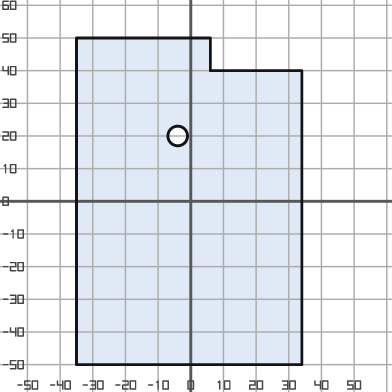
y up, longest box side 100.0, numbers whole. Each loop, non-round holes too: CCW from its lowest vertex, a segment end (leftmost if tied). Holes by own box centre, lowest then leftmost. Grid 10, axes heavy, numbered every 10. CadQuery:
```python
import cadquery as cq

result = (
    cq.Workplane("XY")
    .moveTo(-35.0, -50.0)
    .lineTo(34.0, -50.0)
    .lineTo(34.0, 40.0)
    .lineTo(6.0, 40.0)
    .lineTo(6.0, 50.0)
    .lineTo(-35.0, 50.0)
    .close()
    .moveTo(-4.0, 20.0)
    .circle(3.0)
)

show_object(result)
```